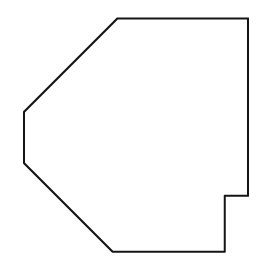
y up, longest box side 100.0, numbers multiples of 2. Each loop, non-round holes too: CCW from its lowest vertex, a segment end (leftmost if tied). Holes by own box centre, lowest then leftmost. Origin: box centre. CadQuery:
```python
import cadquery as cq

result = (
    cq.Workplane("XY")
    .moveTo(-10.0, -50.0)
    .lineTo(38.0, -50.0)
    .lineTo(38.0, -26.0)
    .lineTo(48.0, -26.0)
    .lineTo(48.0, 50.0)
    .lineTo(-8.0, 50.0)
    .lineTo(-48.0, 10.0)
    .lineTo(-48.0, -12.0)
    .close()
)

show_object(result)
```